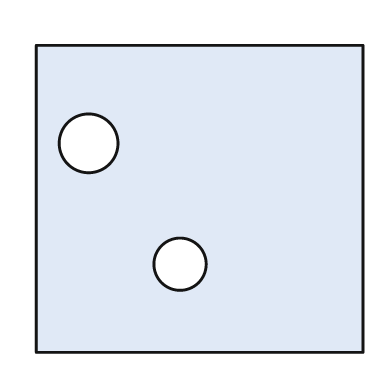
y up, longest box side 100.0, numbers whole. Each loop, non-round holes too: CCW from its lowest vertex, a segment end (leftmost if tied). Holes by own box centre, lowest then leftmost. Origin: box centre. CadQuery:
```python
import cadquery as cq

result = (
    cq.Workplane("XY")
    .moveTo(-50.0, -47.0)
    .lineTo(50.0, -47.0)
    .lineTo(50.0, 47.0)
    .lineTo(-50.0, 47.0)
    .close()
    .moveTo(-6.0, -20.0)
    .circle(8.0)
    .moveTo(-34.0, 17.0)
    .circle(9.0)
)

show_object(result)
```